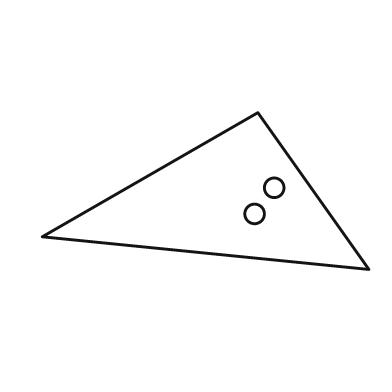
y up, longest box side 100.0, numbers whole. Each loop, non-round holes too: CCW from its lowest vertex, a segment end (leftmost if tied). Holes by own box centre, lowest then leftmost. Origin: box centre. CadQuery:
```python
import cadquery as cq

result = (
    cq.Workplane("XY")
    .moveTo(50.0, -24.0)
    .lineTo(16.0, 24.0)
    .lineTo(-50.0, -14.0)
    .close()
    .moveTo(15.0, -7.0)
    .circle(3.0)
    .moveTo(21.0, 1.0)
    .circle(3.0)
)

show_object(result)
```